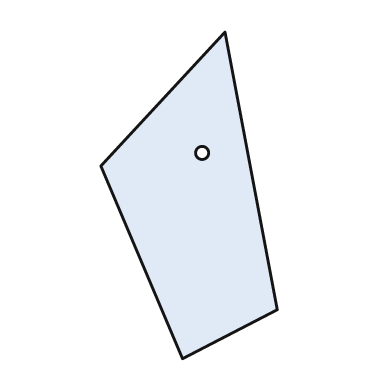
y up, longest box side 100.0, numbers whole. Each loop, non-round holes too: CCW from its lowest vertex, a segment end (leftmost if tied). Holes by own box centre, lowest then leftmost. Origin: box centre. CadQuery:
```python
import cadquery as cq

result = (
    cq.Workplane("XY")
    .moveTo(-2.0, -50.0)
    .lineTo(27.0, -35.0)
    .lineTo(11.0, 50.0)
    .lineTo(-27.0, 9.0)
    .close()
    .moveTo(4.0, 13.0)
    .circle(2.0)
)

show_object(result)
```